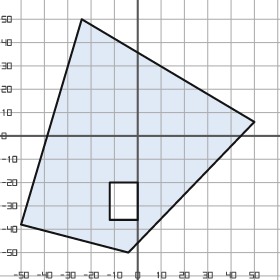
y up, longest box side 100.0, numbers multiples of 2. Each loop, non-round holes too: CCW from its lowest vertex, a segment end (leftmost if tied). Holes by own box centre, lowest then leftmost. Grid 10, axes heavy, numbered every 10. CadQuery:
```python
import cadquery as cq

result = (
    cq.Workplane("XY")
    .moveTo(-4.0, -50.0)
    .lineTo(50.0, 6.0)
    .lineTo(-24.0, 50.0)
    .lineTo(-50.0, -38.0)
    .close()
    .moveTo(-12.0, -36.0)
    .lineTo(0.0, -36.0)
    .lineTo(0.0, -20.0)
    .lineTo(-12.0, -20.0)
    .close()
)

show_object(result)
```